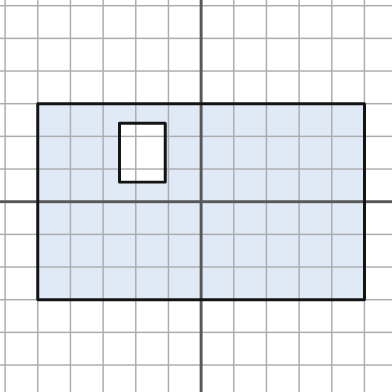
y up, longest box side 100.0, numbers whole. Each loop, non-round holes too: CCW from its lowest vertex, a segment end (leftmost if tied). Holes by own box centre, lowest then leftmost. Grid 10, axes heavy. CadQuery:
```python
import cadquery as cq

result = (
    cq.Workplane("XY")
    .moveTo(-50.0, -30.0)
    .lineTo(50.0, -30.0)
    .lineTo(50.0, 30.0)
    .lineTo(-50.0, 30.0)
    .close()
    .moveTo(-25.0, 6.0)
    .lineTo(-11.0, 6.0)
    .lineTo(-11.0, 24.0)
    .lineTo(-25.0, 24.0)
    .close()
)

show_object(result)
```